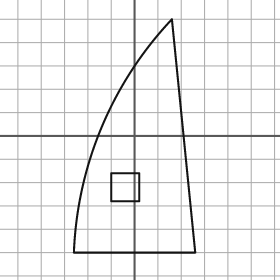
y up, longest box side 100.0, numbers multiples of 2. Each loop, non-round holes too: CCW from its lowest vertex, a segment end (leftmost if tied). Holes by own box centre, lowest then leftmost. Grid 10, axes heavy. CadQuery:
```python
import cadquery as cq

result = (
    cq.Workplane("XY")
    .moveTo(-26.0, -50.0)
    .lineTo(26.0, -50.0)
    .lineTo(16.0, 50.0)
    .threePointArc((-14.0, 4.0), (-26.0, -50.0))
    .close()
    .moveTo(-10.0, -28.0)
    .lineTo(2.0, -28.0)
    .lineTo(2.0, -16.0)
    .lineTo(-10.0, -16.0)
    .close()
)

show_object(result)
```